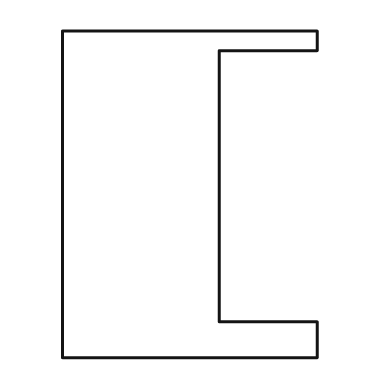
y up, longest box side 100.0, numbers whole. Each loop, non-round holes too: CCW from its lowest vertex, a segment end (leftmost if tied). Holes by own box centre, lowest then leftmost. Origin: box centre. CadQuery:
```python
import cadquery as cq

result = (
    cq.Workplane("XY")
    .moveTo(-39.0, -50.0)
    .lineTo(39.0, -50.0)
    .lineTo(39.0, -39.0)
    .lineTo(9.0, -39.0)
    .lineTo(9.0, 44.0)
    .lineTo(39.0, 44.0)
    .lineTo(39.0, 50.0)
    .lineTo(-39.0, 50.0)
    .close()
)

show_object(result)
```